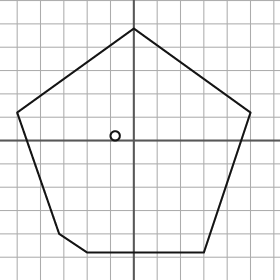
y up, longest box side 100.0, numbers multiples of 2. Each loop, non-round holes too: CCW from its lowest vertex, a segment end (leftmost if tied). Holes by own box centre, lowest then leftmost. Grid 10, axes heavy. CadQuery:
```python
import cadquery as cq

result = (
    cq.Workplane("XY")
    .moveTo(-20.0, -48.0)
    .lineTo(30.0, -48.0)
    .lineTo(50.0, 12.0)
    .lineTo(0.0, 48.0)
    .lineTo(-50.0, 12.0)
    .lineTo(-32.0, -40.0)
    .close()
    .moveTo(-8.0, 2.0)
    .circle(2.0)
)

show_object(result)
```